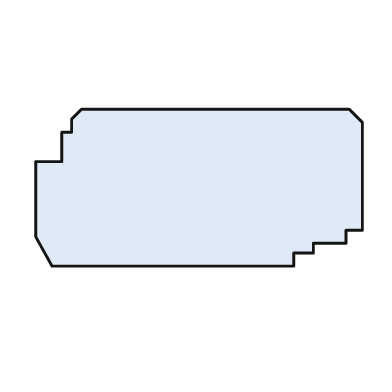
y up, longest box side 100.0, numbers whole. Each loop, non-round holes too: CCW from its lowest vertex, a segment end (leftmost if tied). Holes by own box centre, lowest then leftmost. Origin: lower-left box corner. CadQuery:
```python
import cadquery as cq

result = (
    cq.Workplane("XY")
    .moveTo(5.0, 0.0)
    .lineTo(79.0, 0.0)
    .lineTo(79.0, 4.0)
    .lineTo(85.0, 4.0)
    .lineTo(85.0, 7.0)
    .lineTo(95.0, 7.0)
    .lineTo(95.0, 11.0)
    .lineTo(100.0, 11.0)
    .lineTo(100.0, 44.0)
    .lineTo(96.0, 48.0)
    .lineTo(14.0, 48.0)
    .lineTo(11.0, 45.0)
    .lineTo(11.0, 41.0)
    .lineTo(8.0, 41.0)
    .lineTo(8.0, 32.0)
    .lineTo(0.0, 32.0)
    .lineTo(0.0, 9.0)
    .close()
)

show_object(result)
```